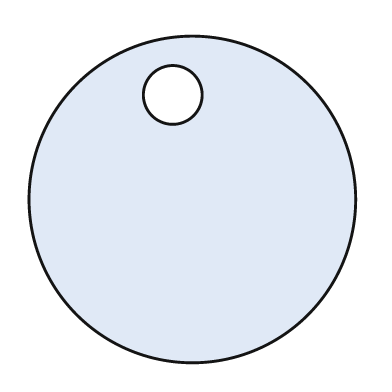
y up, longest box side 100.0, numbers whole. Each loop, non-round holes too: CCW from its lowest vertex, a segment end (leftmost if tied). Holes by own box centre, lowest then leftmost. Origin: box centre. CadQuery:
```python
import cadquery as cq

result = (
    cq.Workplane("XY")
    .moveTo(0.0, 0.0)
    .circle(50.0)
    .moveTo(-6.0, 32.0)
    .circle(9.0)
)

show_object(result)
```